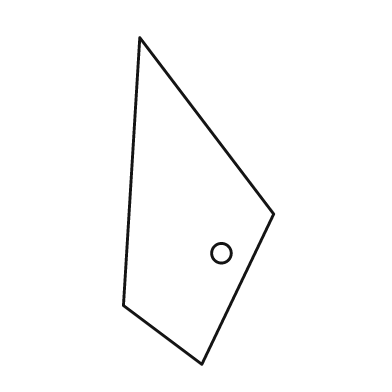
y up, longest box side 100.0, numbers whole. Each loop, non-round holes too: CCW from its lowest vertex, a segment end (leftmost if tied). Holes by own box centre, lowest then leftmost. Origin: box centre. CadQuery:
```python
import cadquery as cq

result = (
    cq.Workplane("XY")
    .moveTo(1.0, -50.0)
    .lineTo(23.0, -4.0)
    .lineTo(-18.0, 50.0)
    .lineTo(-23.0, -32.0)
    .close()
    .moveTo(7.0, -16.0)
    .circle(3.0)
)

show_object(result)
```